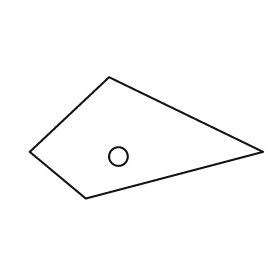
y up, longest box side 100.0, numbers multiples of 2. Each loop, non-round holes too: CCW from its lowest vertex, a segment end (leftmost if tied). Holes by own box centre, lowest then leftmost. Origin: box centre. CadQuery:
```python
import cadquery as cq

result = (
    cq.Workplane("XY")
    .moveTo(-26.0, -26.0)
    .lineTo(50.0, -6.0)
    .lineTo(-16.0, 26.0)
    .lineTo(-50.0, -6.0)
    .close()
    .moveTo(-12.0, -8.0)
    .circle(4.0)
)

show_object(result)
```